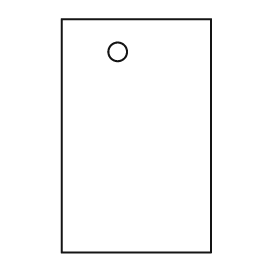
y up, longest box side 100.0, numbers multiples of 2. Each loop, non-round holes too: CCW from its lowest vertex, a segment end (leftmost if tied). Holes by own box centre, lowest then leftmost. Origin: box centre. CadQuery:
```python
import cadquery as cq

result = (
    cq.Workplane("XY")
    .moveTo(-32.0, -50.0)
    .lineTo(32.0, -50.0)
    .lineTo(32.0, 50.0)
    .lineTo(-32.0, 50.0)
    .close()
    .moveTo(-8.0, 36.0)
    .circle(4.0)
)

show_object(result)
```